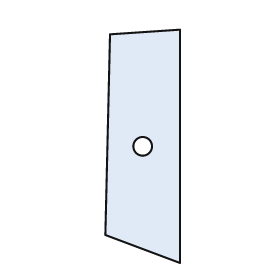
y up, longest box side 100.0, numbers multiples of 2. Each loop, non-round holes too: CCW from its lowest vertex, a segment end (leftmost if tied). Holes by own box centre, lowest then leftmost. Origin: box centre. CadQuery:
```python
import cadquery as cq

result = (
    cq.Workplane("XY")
    .moveTo(16.0, -50.0)
    .lineTo(16.0, 50.0)
    .lineTo(-14.0, 48.0)
    .lineTo(-16.0, -38.0)
    .close()
    .moveTo(0.0, 0.0)
    .circle(4.0)
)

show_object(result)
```